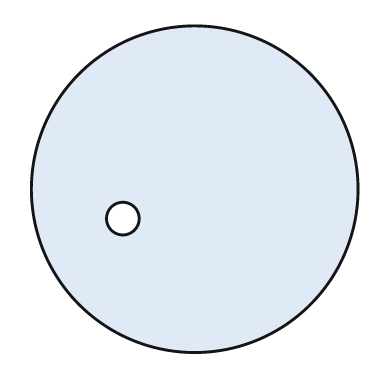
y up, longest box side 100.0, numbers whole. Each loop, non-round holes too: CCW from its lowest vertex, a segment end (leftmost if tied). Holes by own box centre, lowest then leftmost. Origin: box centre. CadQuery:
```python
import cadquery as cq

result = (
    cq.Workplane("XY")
    .moveTo(0.0, 0.0)
    .circle(50.0)
    .moveTo(-22.0, -9.0)
    .circle(5.0)
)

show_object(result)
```